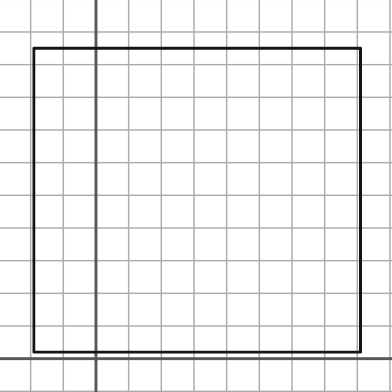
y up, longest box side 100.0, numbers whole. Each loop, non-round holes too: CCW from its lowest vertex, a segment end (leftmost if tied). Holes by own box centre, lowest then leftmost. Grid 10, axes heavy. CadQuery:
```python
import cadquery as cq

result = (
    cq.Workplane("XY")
    .moveTo(-19.0, 2.0)
    .lineTo(81.0, 2.0)
    .lineTo(81.0, 95.0)
    .lineTo(-19.0, 95.0)
    .close()
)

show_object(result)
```